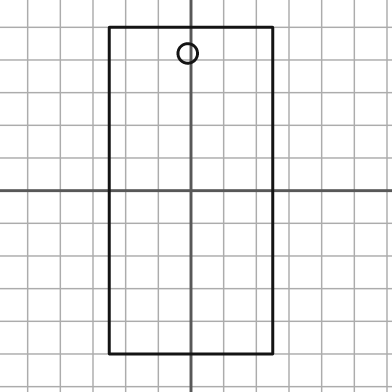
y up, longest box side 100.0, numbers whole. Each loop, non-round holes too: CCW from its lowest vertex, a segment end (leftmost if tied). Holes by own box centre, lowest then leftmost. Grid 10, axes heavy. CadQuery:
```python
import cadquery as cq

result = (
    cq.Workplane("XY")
    .moveTo(-25.0, -50.0)
    .lineTo(25.0, -50.0)
    .lineTo(25.0, 50.0)
    .lineTo(-25.0, 50.0)
    .close()
    .moveTo(-1.0, 42.0)
    .circle(3.0)
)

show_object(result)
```